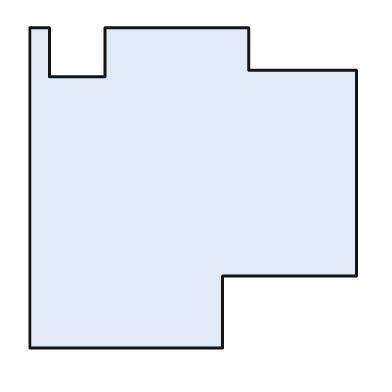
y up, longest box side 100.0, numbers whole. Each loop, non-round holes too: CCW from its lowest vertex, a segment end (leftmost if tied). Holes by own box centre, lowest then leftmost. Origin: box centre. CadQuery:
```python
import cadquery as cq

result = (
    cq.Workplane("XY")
    .moveTo(-50.0, -49.0)
    .lineTo(9.0, -49.0)
    .lineTo(9.0, -27.0)
    .lineTo(50.0, -27.0)
    .lineTo(50.0, 36.0)
    .lineTo(17.0, 36.0)
    .lineTo(17.0, 49.0)
    .lineTo(-27.0, 49.0)
    .lineTo(-27.0, 34.0)
    .lineTo(-44.0, 34.0)
    .lineTo(-44.0, 49.0)
    .lineTo(-50.0, 49.0)
    .close()
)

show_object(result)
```